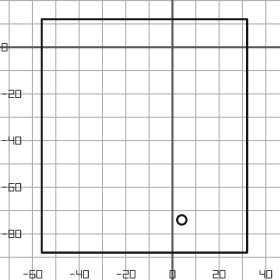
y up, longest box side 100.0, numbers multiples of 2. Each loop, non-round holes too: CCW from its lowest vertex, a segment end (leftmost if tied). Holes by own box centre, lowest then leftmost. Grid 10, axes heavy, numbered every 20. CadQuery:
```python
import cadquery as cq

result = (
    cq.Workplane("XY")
    .moveTo(-56.0, -88.0)
    .lineTo(32.0, -88.0)
    .lineTo(32.0, 12.0)
    .lineTo(-56.0, 12.0)
    .close()
    .moveTo(4.0, -74.0)
    .circle(2.0)
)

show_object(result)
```